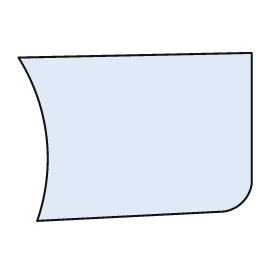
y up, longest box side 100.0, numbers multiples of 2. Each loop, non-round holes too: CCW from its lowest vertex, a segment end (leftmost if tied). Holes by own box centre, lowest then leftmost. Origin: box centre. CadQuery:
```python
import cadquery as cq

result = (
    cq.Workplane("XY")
    .moveTo(-42.0, -36.0)
    .lineTo(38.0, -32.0)
    .threePointArc((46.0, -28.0), (50.0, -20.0))
    .lineTo(50.0, 36.0)
    .lineTo(-50.0, 34.0)
    .threePointArc((-38.0, 0.0), (-42.0, -36.0))
    .close()
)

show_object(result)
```